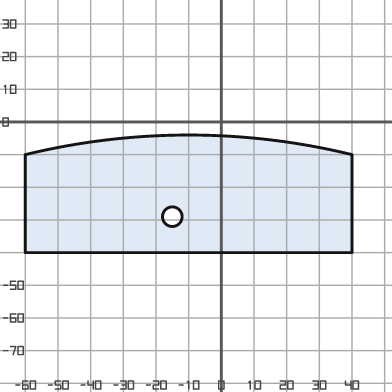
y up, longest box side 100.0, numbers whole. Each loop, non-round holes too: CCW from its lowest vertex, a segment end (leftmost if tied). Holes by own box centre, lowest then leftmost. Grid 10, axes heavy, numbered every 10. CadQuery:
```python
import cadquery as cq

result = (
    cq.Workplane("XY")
    .moveTo(-60.0, -40.0)
    .lineTo(40.0, -40.0)
    .lineTo(40.0, -10.0)
    .threePointArc((-10.0, -4.0), (-60.0, -10.0))
    .close()
    .moveTo(-15.0, -29.0)
    .circle(3.0)
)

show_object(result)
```